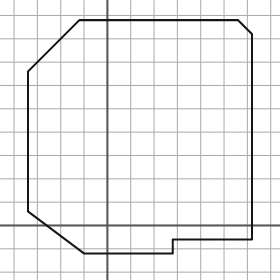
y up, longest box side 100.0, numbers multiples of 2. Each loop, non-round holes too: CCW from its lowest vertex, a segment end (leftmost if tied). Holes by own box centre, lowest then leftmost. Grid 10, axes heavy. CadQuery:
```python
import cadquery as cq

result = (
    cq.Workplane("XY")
    .moveTo(-10.0, -12.0)
    .lineTo(28.0, -12.0)
    .lineTo(28.0, -6.0)
    .lineTo(62.0, -6.0)
    .lineTo(62.0, 82.0)
    .lineTo(56.0, 88.0)
    .lineTo(-12.0, 88.0)
    .lineTo(-34.0, 66.0)
    .lineTo(-34.0, 6.0)
    .close()
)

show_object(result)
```